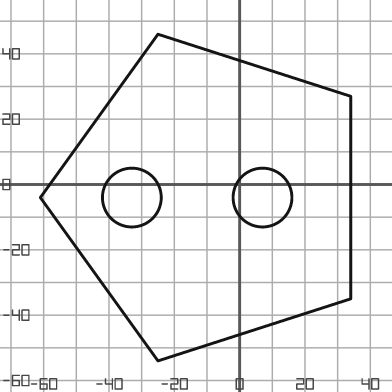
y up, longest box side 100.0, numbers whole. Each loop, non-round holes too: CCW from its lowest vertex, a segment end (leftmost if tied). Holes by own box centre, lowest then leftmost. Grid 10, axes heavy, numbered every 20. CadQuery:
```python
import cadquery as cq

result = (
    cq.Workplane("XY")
    .moveTo(-25.0, -54.0)
    .lineTo(34.0, -35.0)
    .lineTo(34.0, 27.0)
    .lineTo(-25.0, 46.0)
    .lineTo(-61.0, -4.0)
    .close()
    .moveTo(-33.0, -4.0)
    .circle(9.0)
    .moveTo(7.0, -4.0)
    .circle(9.0)
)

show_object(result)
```